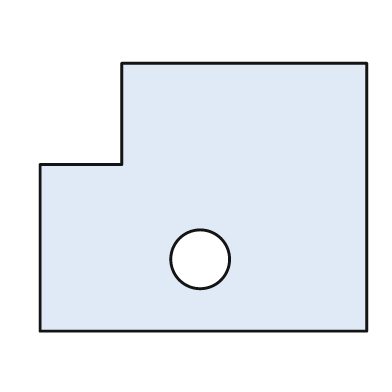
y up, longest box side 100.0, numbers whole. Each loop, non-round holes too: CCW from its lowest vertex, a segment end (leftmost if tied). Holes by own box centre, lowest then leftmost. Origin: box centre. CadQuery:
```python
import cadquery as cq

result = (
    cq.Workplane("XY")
    .moveTo(-50.0, -41.0)
    .lineTo(50.0, -41.0)
    .lineTo(50.0, 41.0)
    .lineTo(-25.0, 41.0)
    .lineTo(-25.0, 10.0)
    .lineTo(-50.0, 10.0)
    .close()
    .moveTo(-1.0, -19.0)
    .circle(9.0)
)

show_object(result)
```